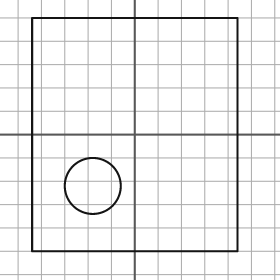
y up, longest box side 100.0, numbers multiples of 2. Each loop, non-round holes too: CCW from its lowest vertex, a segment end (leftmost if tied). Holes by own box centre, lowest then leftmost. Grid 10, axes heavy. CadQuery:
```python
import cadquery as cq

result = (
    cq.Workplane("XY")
    .moveTo(-44.0, -50.0)
    .lineTo(44.0, -50.0)
    .lineTo(44.0, 50.0)
    .lineTo(-44.0, 50.0)
    .close()
    .moveTo(-18.0, -22.0)
    .circle(12.0)
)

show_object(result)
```